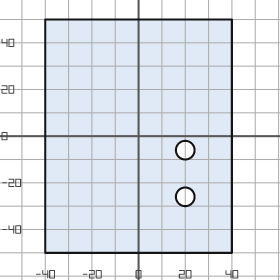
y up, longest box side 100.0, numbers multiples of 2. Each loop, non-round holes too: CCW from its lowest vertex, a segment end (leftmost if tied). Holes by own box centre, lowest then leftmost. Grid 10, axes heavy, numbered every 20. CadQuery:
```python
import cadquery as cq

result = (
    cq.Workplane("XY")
    .moveTo(-40.0, -50.0)
    .lineTo(40.0, -50.0)
    .lineTo(40.0, 50.0)
    .lineTo(-40.0, 50.0)
    .close()
    .moveTo(20.0, -26.0)
    .circle(4.0)
    .moveTo(20.0, -6.0)
    .circle(4.0)
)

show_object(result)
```